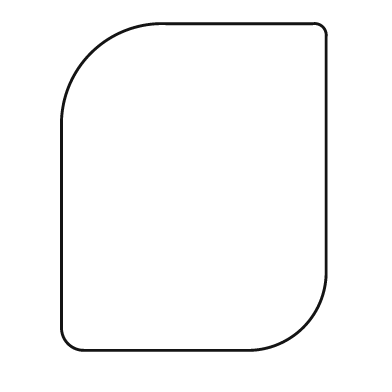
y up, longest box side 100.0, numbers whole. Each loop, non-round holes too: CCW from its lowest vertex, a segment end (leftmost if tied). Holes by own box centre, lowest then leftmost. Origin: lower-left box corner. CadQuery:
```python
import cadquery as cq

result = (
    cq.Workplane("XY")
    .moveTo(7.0, 0.0)
    .lineTo(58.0, 0.0)
    .threePointArc((74.0, 7.0), (81.0, 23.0))
    .lineTo(81.0, 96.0)
    .threePointArc((80.0, 99.0), (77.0, 100.0))
    .lineTo(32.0, 100.0)
    .threePointArc((9.0, 91.0), (0.0, 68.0))
    .lineTo(0.0, 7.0)
    .threePointArc((2.0, 2.0), (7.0, 0.0))
    .close()
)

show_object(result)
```